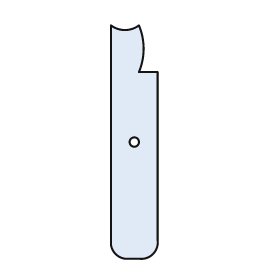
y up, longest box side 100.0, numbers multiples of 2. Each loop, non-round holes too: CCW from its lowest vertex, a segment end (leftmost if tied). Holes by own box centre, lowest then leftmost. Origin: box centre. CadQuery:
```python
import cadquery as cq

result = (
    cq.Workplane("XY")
    .moveTo(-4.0, -50.0)
    .lineTo(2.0, -50.0)
    .threePointArc((8.0, -48.0), (10.0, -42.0))
    .lineTo(10.0, 30.0)
    .lineTo(2.0, 30.0)
    .threePointArc((4.0, 40.0), (2.0, 50.0))
    .threePointArc((-4.0, 48.0), (-10.0, 50.0))
    .lineTo(-10.0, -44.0)
    .threePointArc((-8.0, -48.0), (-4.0, -50.0))
    .close()
    .moveTo(0.0, 0.0)
    .circle(2.0)
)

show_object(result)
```